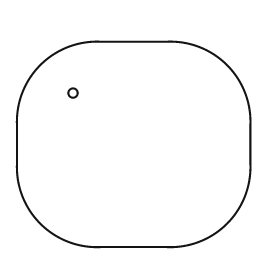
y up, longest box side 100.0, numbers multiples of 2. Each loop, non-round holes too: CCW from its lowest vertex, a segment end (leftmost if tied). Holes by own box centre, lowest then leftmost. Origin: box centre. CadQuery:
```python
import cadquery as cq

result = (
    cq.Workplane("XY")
    .moveTo(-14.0, -44.0)
    .lineTo(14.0, -44.0)
    .threePointArc((40.0, -34.0), (50.0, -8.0))
    .lineTo(50.0, 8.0)
    .threePointArc((40.0, 34.0), (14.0, 44.0))
    .lineTo(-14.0, 44.0)
    .threePointArc((-40.0, 34.0), (-50.0, 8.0))
    .lineTo(-50.0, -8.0)
    .threePointArc((-40.0, -34.0), (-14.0, -44.0))
    .close()
    .moveTo(-26.0, 22.0)
    .circle(2.0)
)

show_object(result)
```